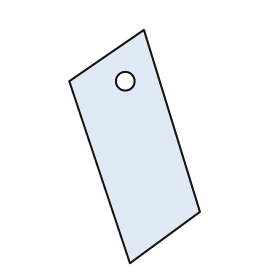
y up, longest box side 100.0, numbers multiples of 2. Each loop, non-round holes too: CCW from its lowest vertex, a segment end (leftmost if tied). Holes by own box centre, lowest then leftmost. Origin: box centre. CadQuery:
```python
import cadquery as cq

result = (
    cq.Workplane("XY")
    .moveTo(-2.0, -50.0)
    .lineTo(28.0, -28.0)
    .lineTo(4.0, 50.0)
    .lineTo(-28.0, 28.0)
    .close()
    .moveTo(-4.0, 28.0)
    .circle(4.0)
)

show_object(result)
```